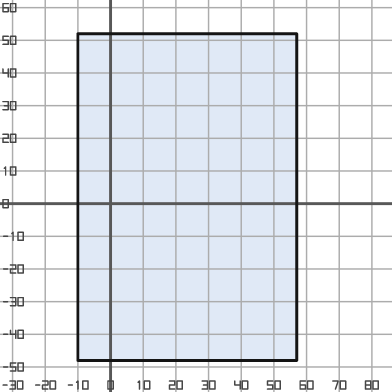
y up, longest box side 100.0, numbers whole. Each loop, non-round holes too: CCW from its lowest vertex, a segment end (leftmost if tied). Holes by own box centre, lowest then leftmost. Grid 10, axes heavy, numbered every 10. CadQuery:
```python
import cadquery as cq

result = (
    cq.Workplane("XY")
    .moveTo(-10.0, -48.0)
    .lineTo(57.0, -48.0)
    .lineTo(57.0, 52.0)
    .lineTo(-10.0, 52.0)
    .close()
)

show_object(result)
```